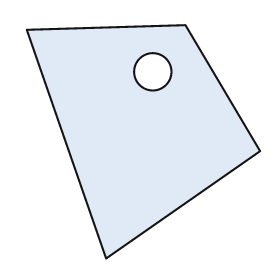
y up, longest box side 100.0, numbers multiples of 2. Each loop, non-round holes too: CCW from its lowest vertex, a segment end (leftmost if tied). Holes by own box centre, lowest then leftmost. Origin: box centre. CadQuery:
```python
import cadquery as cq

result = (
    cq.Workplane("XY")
    .moveTo(-16.0, -50.0)
    .lineTo(50.0, -4.0)
    .lineTo(18.0, 50.0)
    .lineTo(-50.0, 48.0)
    .close()
    .moveTo(4.0, 30.0)
    .circle(8.0)
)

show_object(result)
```